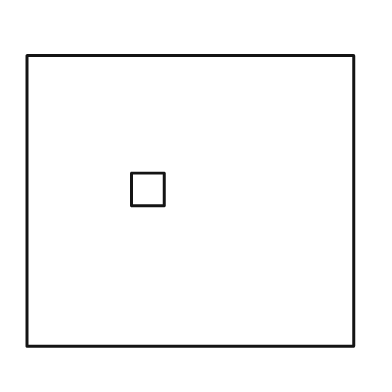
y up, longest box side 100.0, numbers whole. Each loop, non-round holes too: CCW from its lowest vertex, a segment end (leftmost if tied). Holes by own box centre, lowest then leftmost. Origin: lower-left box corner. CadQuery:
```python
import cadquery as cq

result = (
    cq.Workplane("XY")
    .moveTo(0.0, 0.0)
    .lineTo(100.0, 0.0)
    .lineTo(100.0, 89.0)
    .lineTo(0.0, 89.0)
    .close()
    .moveTo(32.0, 43.0)
    .lineTo(42.0, 43.0)
    .lineTo(42.0, 53.0)
    .lineTo(32.0, 53.0)
    .close()
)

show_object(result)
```